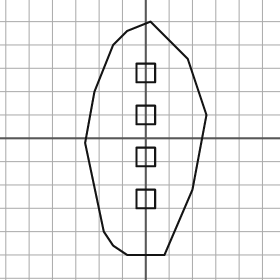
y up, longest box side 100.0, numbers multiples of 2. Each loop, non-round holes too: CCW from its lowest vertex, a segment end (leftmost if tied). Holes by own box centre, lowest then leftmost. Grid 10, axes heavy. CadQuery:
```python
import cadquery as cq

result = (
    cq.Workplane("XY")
    .moveTo(-8.0, -50.0)
    .lineTo(8.0, -50.0)
    .lineTo(20.0, -22.0)
    .lineTo(26.0, 10.0)
    .lineTo(18.0, 34.0)
    .lineTo(2.0, 50.0)
    .lineTo(-8.0, 46.0)
    .lineTo(-14.0, 40.0)
    .lineTo(-22.0, 20.0)
    .lineTo(-26.0, -2.0)
    .lineTo(-18.0, -40.0)
    .lineTo(-14.0, -46.0)
    .close()
    .moveTo(-4.0, -30.0)
    .lineTo(4.0, -30.0)
    .lineTo(4.0, -22.0)
    .lineTo(-4.0, -22.0)
    .close()
    .moveTo(-4.0, -12.0)
    .lineTo(4.0, -12.0)
    .lineTo(4.0, -4.0)
    .lineTo(-4.0, -4.0)
    .close()
    .moveTo(-4.0, 6.0)
    .lineTo(4.0, 6.0)
    .lineTo(4.0, 14.0)
    .lineTo(-4.0, 14.0)
    .close()
    .moveTo(-4.0, 24.0)
    .lineTo(4.0, 24.0)
    .lineTo(4.0, 32.0)
    .lineTo(-4.0, 32.0)
    .close()
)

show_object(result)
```